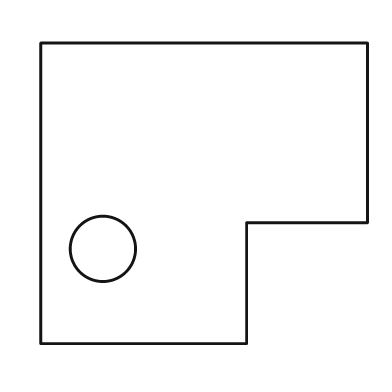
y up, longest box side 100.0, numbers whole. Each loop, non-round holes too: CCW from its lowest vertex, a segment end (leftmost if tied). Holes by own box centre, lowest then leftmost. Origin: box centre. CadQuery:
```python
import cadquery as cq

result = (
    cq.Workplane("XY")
    .moveTo(-50.0, -46.0)
    .lineTo(13.0, -46.0)
    .lineTo(13.0, -9.0)
    .lineTo(50.0, -9.0)
    .lineTo(50.0, 46.0)
    .lineTo(-50.0, 46.0)
    .close()
    .moveTo(-31.0, -17.0)
    .circle(10.0)
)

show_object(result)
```